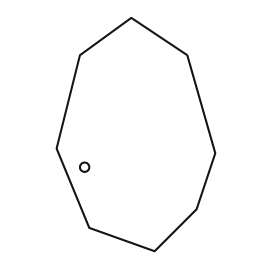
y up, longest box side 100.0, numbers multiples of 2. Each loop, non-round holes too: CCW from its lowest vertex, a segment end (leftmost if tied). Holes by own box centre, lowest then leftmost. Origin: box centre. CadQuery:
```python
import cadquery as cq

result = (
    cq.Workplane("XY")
    .moveTo(8.0, -50.0)
    .lineTo(26.0, -32.0)
    .lineTo(34.0, -8.0)
    .lineTo(22.0, 34.0)
    .lineTo(-2.0, 50.0)
    .lineTo(-24.0, 34.0)
    .lineTo(-34.0, -6.0)
    .lineTo(-20.0, -40.0)
    .close()
    .moveTo(-22.0, -14.0)
    .circle(2.0)
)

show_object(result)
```